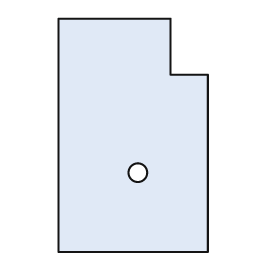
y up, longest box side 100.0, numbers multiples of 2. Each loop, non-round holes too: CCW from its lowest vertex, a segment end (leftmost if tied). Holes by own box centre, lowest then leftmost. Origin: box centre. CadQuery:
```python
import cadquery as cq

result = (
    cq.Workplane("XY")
    .moveTo(-32.0, -50.0)
    .lineTo(32.0, -50.0)
    .lineTo(32.0, 26.0)
    .lineTo(16.0, 26.0)
    .lineTo(16.0, 50.0)
    .lineTo(-32.0, 50.0)
    .close()
    .moveTo(2.0, -16.0)
    .circle(4.0)
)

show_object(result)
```